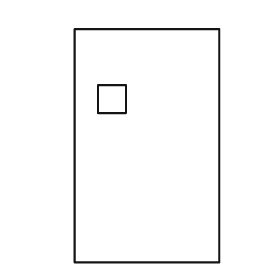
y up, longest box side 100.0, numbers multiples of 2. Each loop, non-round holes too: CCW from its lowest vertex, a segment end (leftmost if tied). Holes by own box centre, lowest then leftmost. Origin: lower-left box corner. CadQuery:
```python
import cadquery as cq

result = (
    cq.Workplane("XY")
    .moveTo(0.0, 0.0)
    .lineTo(62.0, 0.0)
    .lineTo(62.0, 100.0)
    .lineTo(0.0, 100.0)
    .close()
    .moveTo(10.0, 64.0)
    .lineTo(22.0, 64.0)
    .lineTo(22.0, 76.0)
    .lineTo(10.0, 76.0)
    .close()
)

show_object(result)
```